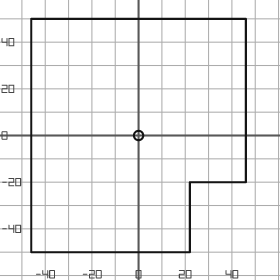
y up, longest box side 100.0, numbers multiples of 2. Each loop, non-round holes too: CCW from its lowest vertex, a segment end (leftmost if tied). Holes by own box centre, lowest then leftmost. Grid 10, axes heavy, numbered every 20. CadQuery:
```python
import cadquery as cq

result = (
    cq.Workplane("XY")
    .moveTo(-46.0, -50.0)
    .lineTo(22.0, -50.0)
    .lineTo(22.0, -20.0)
    .lineTo(46.0, -20.0)
    .lineTo(46.0, 50.0)
    .lineTo(-46.0, 50.0)
    .close()
    .moveTo(0.0, 0.0)
    .circle(2.0)
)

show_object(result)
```